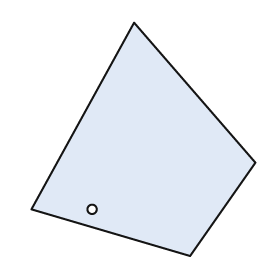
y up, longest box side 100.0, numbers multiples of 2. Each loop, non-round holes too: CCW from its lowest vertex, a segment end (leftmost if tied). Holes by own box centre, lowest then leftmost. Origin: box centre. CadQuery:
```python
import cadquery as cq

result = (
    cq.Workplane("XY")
    .moveTo(20.0, -50.0)
    .lineTo(48.0, -10.0)
    .lineTo(-4.0, 50.0)
    .lineTo(-48.0, -30.0)
    .close()
    .moveTo(-22.0, -30.0)
    .circle(2.0)
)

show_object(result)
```